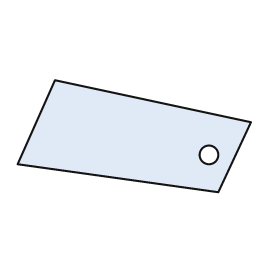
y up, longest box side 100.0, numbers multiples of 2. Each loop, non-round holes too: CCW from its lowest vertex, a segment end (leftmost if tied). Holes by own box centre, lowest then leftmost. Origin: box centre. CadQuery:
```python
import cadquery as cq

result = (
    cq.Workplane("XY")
    .moveTo(36.0, -24.0)
    .lineTo(50.0, 6.0)
    .lineTo(-34.0, 24.0)
    .lineTo(-50.0, -12.0)
    .close()
    .moveTo(32.0, -8.0)
    .circle(4.0)
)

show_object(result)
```